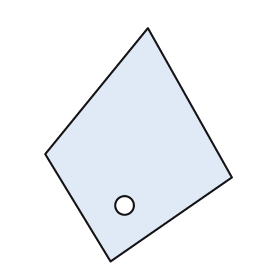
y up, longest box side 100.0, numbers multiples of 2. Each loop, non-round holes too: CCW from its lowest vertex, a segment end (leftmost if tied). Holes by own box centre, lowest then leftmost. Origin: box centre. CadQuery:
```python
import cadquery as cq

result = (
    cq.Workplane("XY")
    .moveTo(-12.0, -50.0)
    .lineTo(40.0, -14.0)
    .lineTo(4.0, 50.0)
    .lineTo(-40.0, -4.0)
    .close()
    .moveTo(-6.0, -26.0)
    .circle(4.0)
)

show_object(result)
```